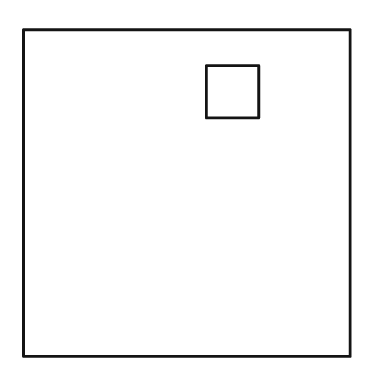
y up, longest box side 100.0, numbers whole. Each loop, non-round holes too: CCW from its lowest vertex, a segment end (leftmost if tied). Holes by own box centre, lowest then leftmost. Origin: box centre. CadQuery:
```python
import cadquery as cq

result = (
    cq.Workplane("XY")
    .moveTo(-50.0, -50.0)
    .lineTo(50.0, -50.0)
    .lineTo(50.0, 50.0)
    .lineTo(-50.0, 50.0)
    .close()
    .moveTo(6.0, 23.0)
    .lineTo(22.0, 23.0)
    .lineTo(22.0, 39.0)
    .lineTo(6.0, 39.0)
    .close()
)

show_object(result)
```